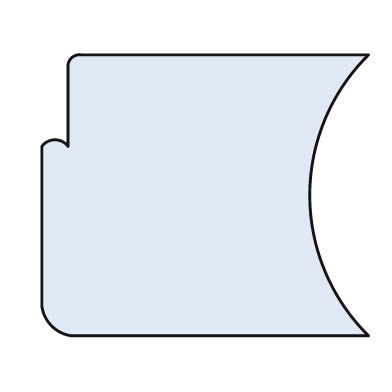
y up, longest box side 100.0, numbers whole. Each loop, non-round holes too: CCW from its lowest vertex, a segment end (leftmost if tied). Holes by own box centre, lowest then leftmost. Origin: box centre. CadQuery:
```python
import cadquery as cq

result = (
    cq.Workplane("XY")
    .moveTo(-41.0, -43.0)
    .lineTo(50.0, -43.0)
    .threePointArc((32.0, 0.0), (50.0, 43.0))
    .lineTo(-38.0, 43.0)
    .threePointArc((-41.0, 42.0), (-42.0, 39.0))
    .lineTo(-42.0, 15.0)
    .threePointArc((-46.0, 17.0), (-50.0, 15.0))
    .lineTo(-50.0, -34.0)
    .threePointArc((-47.0, -40.0), (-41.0, -43.0))
    .close()
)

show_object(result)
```